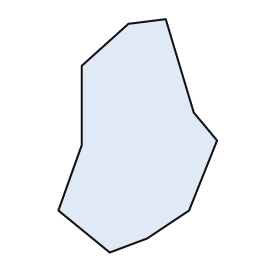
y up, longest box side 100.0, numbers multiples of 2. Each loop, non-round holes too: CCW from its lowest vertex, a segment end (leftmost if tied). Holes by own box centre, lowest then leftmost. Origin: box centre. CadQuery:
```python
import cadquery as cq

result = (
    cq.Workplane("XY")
    .moveTo(-12.0, -50.0)
    .lineTo(4.0, -44.0)
    .lineTo(22.0, -32.0)
    .lineTo(34.0, -2.0)
    .lineTo(24.0, 10.0)
    .lineTo(12.0, 50.0)
    .lineTo(-4.0, 48.0)
    .lineTo(-24.0, 30.0)
    .lineTo(-24.0, -4.0)
    .lineTo(-34.0, -32.0)
    .close()
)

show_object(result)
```